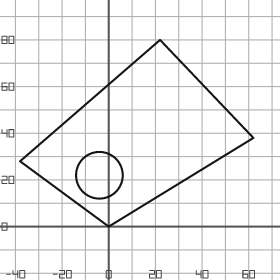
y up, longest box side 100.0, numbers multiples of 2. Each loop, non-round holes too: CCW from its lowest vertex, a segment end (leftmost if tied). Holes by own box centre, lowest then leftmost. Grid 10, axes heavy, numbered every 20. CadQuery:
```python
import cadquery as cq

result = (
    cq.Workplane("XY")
    .moveTo(0.0, 0.0)
    .lineTo(62.0, 38.0)
    .lineTo(22.0, 80.0)
    .lineTo(-38.0, 28.0)
    .close()
    .moveTo(-4.0, 22.0)
    .circle(10.0)
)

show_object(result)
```